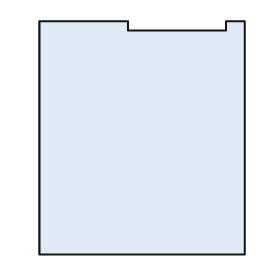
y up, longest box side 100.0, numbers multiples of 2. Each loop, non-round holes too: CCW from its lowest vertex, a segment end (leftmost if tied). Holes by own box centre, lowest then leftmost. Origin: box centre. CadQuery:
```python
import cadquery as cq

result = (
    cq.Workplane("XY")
    .moveTo(-44.0, -50.0)
    .lineTo(44.0, -50.0)
    .lineTo(44.0, 50.0)
    .lineTo(36.0, 50.0)
    .lineTo(36.0, 46.0)
    .lineTo(-6.0, 46.0)
    .lineTo(-6.0, 50.0)
    .lineTo(-44.0, 50.0)
    .close()
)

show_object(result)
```